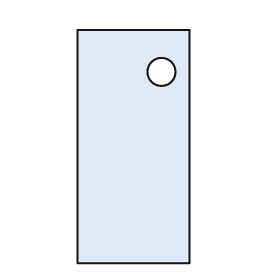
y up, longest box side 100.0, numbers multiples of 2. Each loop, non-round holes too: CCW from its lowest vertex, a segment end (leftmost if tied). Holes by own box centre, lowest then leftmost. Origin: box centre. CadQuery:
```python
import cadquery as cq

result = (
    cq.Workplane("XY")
    .moveTo(-24.0, -50.0)
    .lineTo(24.0, -50.0)
    .lineTo(24.0, 50.0)
    .lineTo(-24.0, 50.0)
    .close()
    .moveTo(12.0, 32.0)
    .circle(6.0)
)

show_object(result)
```